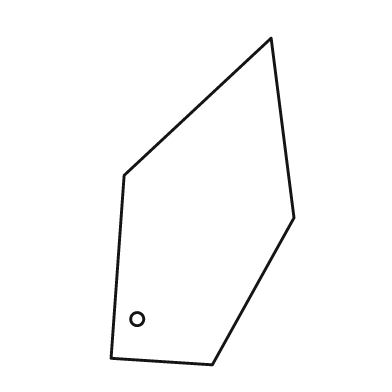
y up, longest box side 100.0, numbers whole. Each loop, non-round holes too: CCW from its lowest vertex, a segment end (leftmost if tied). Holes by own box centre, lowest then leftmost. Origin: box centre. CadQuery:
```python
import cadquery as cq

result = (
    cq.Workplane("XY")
    .moveTo(3.0, -50.0)
    .lineTo(28.0, -5.0)
    .lineTo(21.0, 50.0)
    .lineTo(-24.0, 8.0)
    .lineTo(-28.0, -48.0)
    .close()
    .moveTo(-20.0, -36.0)
    .circle(2.0)
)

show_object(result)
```